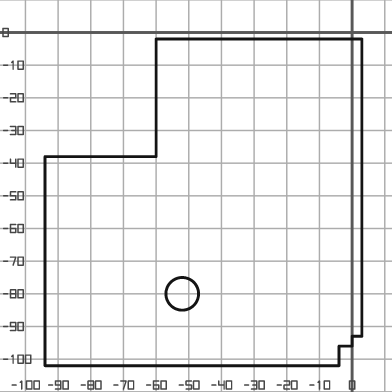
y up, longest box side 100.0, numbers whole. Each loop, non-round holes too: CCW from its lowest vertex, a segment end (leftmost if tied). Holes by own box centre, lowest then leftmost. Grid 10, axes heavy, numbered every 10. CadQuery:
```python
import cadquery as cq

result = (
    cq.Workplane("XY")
    .moveTo(-94.0, -102.0)
    .lineTo(-4.0, -102.0)
    .lineTo(-4.0, -96.0)
    .lineTo(0.0, -96.0)
    .lineTo(0.0, -93.0)
    .lineTo(3.0, -93.0)
    .lineTo(3.0, -2.0)
    .lineTo(-60.0, -2.0)
    .lineTo(-60.0, -38.0)
    .lineTo(-94.0, -38.0)
    .close()
    .moveTo(-52.0, -80.0)
    .circle(5.0)
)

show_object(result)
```